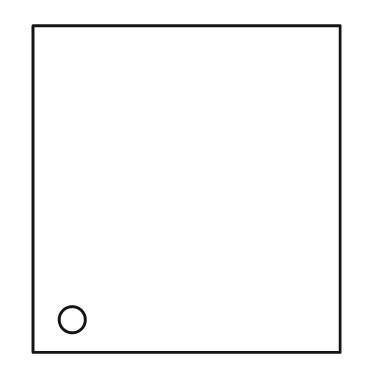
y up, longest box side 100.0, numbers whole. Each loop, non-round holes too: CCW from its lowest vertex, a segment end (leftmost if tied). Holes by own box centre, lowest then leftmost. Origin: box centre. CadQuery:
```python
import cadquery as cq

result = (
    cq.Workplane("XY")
    .moveTo(-47.0, -50.0)
    .lineTo(47.0, -50.0)
    .lineTo(47.0, 50.0)
    .lineTo(-47.0, 50.0)
    .close()
    .moveTo(-35.0, -40.0)
    .circle(4.0)
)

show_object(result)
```